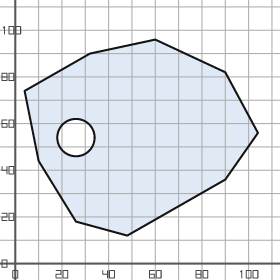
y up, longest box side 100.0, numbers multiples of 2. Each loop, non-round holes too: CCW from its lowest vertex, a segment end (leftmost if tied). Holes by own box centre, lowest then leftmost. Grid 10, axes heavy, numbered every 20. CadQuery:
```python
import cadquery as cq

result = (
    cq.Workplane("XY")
    .moveTo(48.0, 12.0)
    .lineTo(90.0, 36.0)
    .lineTo(104.0, 56.0)
    .lineTo(90.0, 82.0)
    .lineTo(60.0, 96.0)
    .lineTo(32.0, 90.0)
    .lineTo(4.0, 74.0)
    .lineTo(10.0, 44.0)
    .lineTo(26.0, 18.0)
    .close()
    .moveTo(26.0, 54.0)
    .circle(8.0)
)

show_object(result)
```